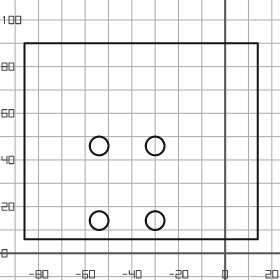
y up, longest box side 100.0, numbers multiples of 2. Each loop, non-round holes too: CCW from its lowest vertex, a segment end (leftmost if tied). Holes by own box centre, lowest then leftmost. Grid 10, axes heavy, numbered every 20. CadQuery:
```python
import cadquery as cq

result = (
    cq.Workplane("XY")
    .moveTo(-86.0, 6.0)
    .lineTo(14.0, 6.0)
    .lineTo(14.0, 90.0)
    .lineTo(-86.0, 90.0)
    .close()
    .moveTo(-54.0, 14.0)
    .circle(4.0)
    .moveTo(-30.0, 14.0)
    .circle(4.0)
    .moveTo(-54.0, 46.0)
    .circle(4.0)
    .moveTo(-30.0, 46.0)
    .circle(4.0)
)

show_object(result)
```